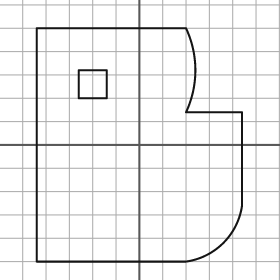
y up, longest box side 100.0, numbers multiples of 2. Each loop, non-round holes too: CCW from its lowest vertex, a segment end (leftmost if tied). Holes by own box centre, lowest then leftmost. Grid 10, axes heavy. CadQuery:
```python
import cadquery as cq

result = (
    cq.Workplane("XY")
    .moveTo(-44.0, -50.0)
    .lineTo(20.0, -50.0)
    .threePointArc((36.0, -42.0), (44.0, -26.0))
    .lineTo(44.0, 14.0)
    .lineTo(20.0, 14.0)
    .threePointArc((24.0, 32.0), (20.0, 50.0))
    .lineTo(-44.0, 50.0)
    .close()
    .moveTo(-26.0, 20.0)
    .lineTo(-14.0, 20.0)
    .lineTo(-14.0, 32.0)
    .lineTo(-26.0, 32.0)
    .close()
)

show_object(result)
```